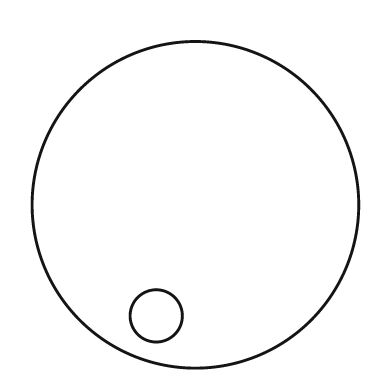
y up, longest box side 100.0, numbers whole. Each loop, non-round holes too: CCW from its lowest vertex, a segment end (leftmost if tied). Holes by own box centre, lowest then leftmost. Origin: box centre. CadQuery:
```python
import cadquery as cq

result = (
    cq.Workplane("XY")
    .moveTo(0.0, 0.0)
    .circle(50.0)
    .moveTo(-12.0, -34.0)
    .circle(8.0)
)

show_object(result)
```